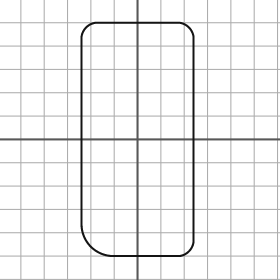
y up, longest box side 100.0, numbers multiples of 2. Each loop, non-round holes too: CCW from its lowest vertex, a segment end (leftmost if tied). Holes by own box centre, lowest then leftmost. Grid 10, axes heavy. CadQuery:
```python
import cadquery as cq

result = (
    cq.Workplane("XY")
    .moveTo(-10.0, -50.0)
    .lineTo(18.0, -50.0)
    .threePointArc((22.0, -48.0), (24.0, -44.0))
    .lineTo(24.0, 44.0)
    .threePointArc((22.0, 48.0), (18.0, 50.0))
    .lineTo(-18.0, 50.0)
    .threePointArc((-22.0, 48.0), (-24.0, 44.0))
    .lineTo(-24.0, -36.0)
    .threePointArc((-20.0, -46.0), (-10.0, -50.0))
    .close()
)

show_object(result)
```